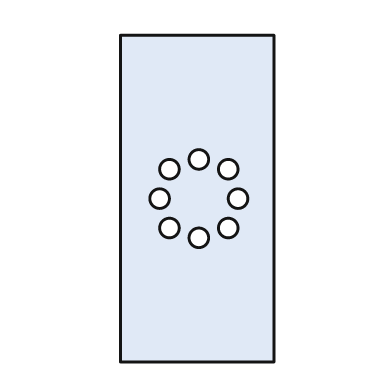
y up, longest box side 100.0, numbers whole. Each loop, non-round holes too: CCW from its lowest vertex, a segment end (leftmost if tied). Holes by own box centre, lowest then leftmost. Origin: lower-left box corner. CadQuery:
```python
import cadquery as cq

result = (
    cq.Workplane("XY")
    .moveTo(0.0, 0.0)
    .lineTo(47.0, 0.0)
    .lineTo(47.0, 100.0)
    .lineTo(0.0, 100.0)
    .close()
    .moveTo(24.0, 38.0)
    .circle(3.0)
    .moveTo(15.0, 41.0)
    .circle(3.0)
    .moveTo(33.0, 41.0)
    .circle(3.0)
    .moveTo(12.0, 50.0)
    .circle(3.0)
    .moveTo(36.0, 50.0)
    .circle(3.0)
    .moveTo(15.0, 59.0)
    .circle(3.0)
    .moveTo(33.0, 59.0)
    .circle(3.0)
    .moveTo(24.0, 62.0)
    .circle(3.0)
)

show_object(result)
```